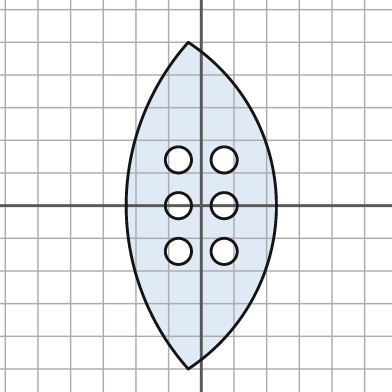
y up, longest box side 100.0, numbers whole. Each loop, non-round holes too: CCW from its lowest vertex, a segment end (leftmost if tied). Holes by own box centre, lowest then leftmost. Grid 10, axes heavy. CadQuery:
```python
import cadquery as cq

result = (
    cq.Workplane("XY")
    .moveTo(-4.0, -50.0)
    .threePointArc((23.0, 0.0), (-4.0, 50.0))
    .threePointArc((-23.0, 0.0), (-4.0, -50.0))
    .close()
    .moveTo(-7.0, -14.0)
    .circle(4.0)
    .moveTo(7.0, -14.0)
    .circle(4.0)
    .moveTo(-7.0, 0.0)
    .circle(4.0)
    .moveTo(7.0, 0.0)
    .circle(4.0)
    .moveTo(-7.0, 14.0)
    .circle(4.0)
    .moveTo(7.0, 14.0)
    .circle(4.0)
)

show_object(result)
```